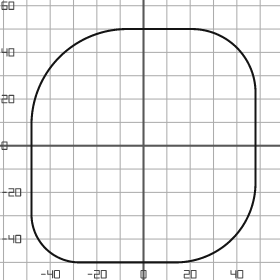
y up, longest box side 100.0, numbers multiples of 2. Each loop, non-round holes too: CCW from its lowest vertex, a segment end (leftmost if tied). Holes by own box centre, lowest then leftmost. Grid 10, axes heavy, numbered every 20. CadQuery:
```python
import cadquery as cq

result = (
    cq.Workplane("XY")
    .moveTo(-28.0, -50.0)
    .lineTo(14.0, -50.0)
    .threePointArc((38.0, -40.0), (48.0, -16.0))
    .lineTo(48.0, 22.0)
    .threePointArc((40.0, 42.0), (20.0, 50.0))
    .lineTo(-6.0, 50.0)
    .threePointArc((-36.0, 38.0), (-48.0, 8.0))
    .lineTo(-48.0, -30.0)
    .threePointArc((-42.0, -44.0), (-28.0, -50.0))
    .close()
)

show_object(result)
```